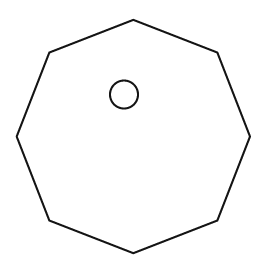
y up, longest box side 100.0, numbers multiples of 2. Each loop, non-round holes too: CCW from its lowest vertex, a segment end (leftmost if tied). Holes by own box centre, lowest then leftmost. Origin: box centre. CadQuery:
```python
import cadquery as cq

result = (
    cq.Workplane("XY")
    .moveTo(0.0, -50.0)
    .lineTo(36.0, -36.0)
    .lineTo(50.0, 0.0)
    .lineTo(36.0, 36.0)
    .lineTo(0.0, 50.0)
    .lineTo(-36.0, 36.0)
    .lineTo(-50.0, 0.0)
    .lineTo(-36.0, -36.0)
    .close()
    .moveTo(-4.0, 18.0)
    .circle(6.0)
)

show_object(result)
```